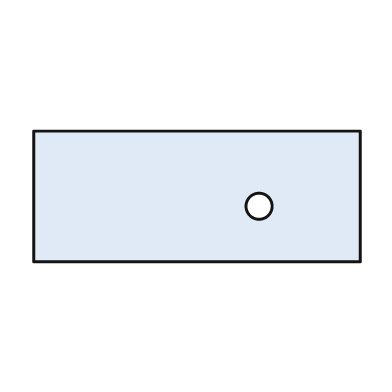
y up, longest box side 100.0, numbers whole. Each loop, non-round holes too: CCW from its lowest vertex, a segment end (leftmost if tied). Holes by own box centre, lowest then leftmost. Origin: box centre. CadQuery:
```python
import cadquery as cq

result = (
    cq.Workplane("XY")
    .moveTo(-50.0, -20.0)
    .lineTo(50.0, -20.0)
    .lineTo(50.0, 20.0)
    .lineTo(-50.0, 20.0)
    .close()
    .moveTo(19.0, -3.0)
    .circle(4.0)
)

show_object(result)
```